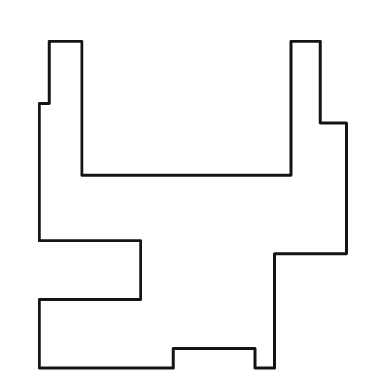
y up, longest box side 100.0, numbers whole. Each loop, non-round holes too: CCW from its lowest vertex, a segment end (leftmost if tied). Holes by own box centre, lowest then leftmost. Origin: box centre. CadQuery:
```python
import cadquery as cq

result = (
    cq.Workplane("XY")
    .moveTo(-47.0, -50.0)
    .lineTo(-6.0, -50.0)
    .lineTo(-6.0, -44.0)
    .lineTo(19.0, -44.0)
    .lineTo(19.0, -50.0)
    .lineTo(25.0, -50.0)
    .lineTo(25.0, -15.0)
    .lineTo(47.0, -15.0)
    .lineTo(47.0, 25.0)
    .lineTo(39.0, 25.0)
    .lineTo(39.0, 50.0)
    .lineTo(30.0, 50.0)
    .lineTo(30.0, 9.0)
    .lineTo(-34.0, 9.0)
    .lineTo(-34.0, 50.0)
    .lineTo(-44.0, 50.0)
    .lineTo(-44.0, 31.0)
    .lineTo(-47.0, 31.0)
    .lineTo(-47.0, -11.0)
    .lineTo(-16.0, -11.0)
    .lineTo(-16.0, -29.0)
    .lineTo(-47.0, -29.0)
    .close()
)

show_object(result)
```